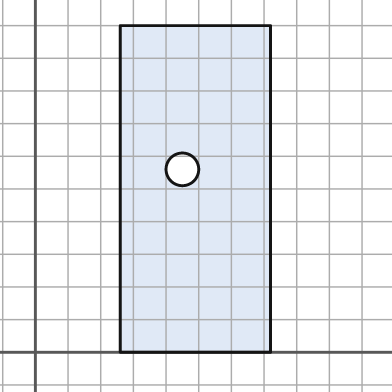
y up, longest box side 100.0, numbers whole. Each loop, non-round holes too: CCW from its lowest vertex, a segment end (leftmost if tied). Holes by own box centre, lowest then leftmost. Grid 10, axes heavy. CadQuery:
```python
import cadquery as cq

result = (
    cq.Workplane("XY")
    .moveTo(26.0, 0.0)
    .lineTo(72.0, 0.0)
    .lineTo(72.0, 100.0)
    .lineTo(26.0, 100.0)
    .close()
    .moveTo(45.0, 56.0)
    .circle(5.0)
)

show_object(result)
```